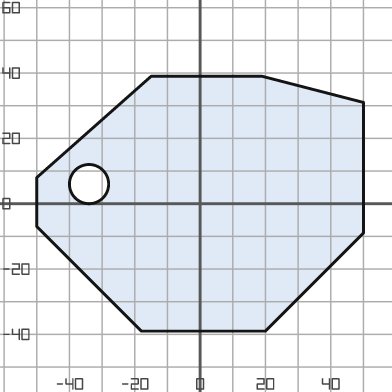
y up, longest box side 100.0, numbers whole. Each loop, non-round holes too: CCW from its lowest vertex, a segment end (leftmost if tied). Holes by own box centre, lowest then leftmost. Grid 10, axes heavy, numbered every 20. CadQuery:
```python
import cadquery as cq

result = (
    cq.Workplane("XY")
    .moveTo(-18.0, -39.0)
    .lineTo(20.0, -39.0)
    .lineTo(50.0, -9.0)
    .lineTo(50.0, 31.0)
    .lineTo(19.0, 39.0)
    .lineTo(-15.0, 39.0)
    .lineTo(-50.0, 8.0)
    .lineTo(-50.0, -7.0)
    .close()
    .moveTo(-34.0, 6.0)
    .circle(6.0)
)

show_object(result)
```